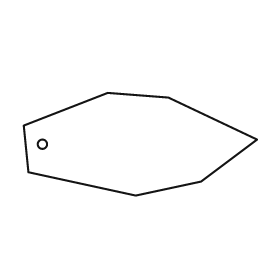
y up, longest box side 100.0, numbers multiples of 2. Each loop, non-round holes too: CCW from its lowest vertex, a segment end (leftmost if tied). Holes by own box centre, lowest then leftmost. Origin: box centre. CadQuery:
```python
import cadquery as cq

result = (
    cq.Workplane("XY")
    .moveTo(-2.0, -22.0)
    .lineTo(26.0, -16.0)
    .lineTo(50.0, 2.0)
    .lineTo(12.0, 20.0)
    .lineTo(-14.0, 22.0)
    .lineTo(-50.0, 8.0)
    .lineTo(-48.0, -12.0)
    .close()
    .moveTo(-42.0, 0.0)
    .circle(2.0)
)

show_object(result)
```